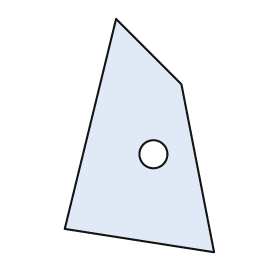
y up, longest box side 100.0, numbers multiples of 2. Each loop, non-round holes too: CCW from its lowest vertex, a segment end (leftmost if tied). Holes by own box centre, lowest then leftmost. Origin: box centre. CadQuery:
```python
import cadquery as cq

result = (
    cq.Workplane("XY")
    .moveTo(32.0, -50.0)
    .lineTo(18.0, 22.0)
    .lineTo(-10.0, 50.0)
    .lineTo(-32.0, -40.0)
    .close()
    .moveTo(6.0, -8.0)
    .circle(6.0)
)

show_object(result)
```